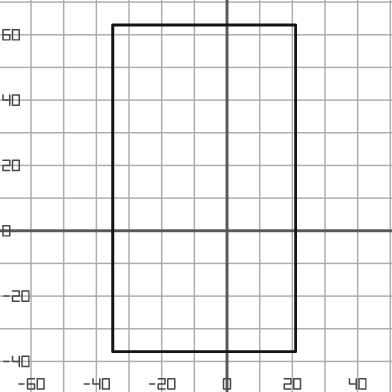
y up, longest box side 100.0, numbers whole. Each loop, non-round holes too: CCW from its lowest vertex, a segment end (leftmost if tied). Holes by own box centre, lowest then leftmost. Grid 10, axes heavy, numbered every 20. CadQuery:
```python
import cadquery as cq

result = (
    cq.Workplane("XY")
    .moveTo(-35.0, -37.0)
    .lineTo(21.0, -37.0)
    .lineTo(21.0, 63.0)
    .lineTo(-35.0, 63.0)
    .close()
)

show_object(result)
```